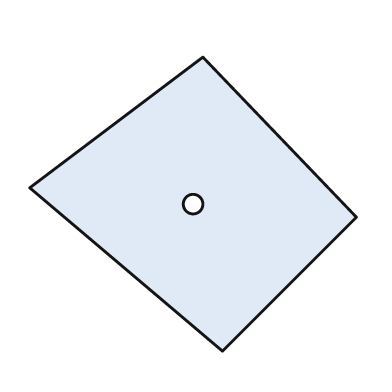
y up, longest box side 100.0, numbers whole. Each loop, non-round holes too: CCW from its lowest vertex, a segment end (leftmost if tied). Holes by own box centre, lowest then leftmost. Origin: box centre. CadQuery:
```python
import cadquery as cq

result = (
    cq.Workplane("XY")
    .moveTo(9.0, -45.0)
    .lineTo(50.0, -4.0)
    .lineTo(3.0, 45.0)
    .lineTo(-50.0, 5.0)
    .close()
    .moveTo(0.0, 0.0)
    .circle(3.0)
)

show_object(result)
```